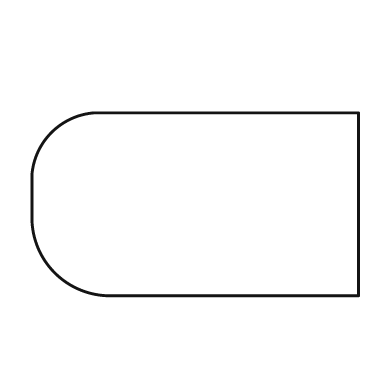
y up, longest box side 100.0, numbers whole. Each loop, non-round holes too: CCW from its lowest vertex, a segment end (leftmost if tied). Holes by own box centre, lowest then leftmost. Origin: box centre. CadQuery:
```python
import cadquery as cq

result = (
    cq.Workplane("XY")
    .moveTo(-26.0, -28.0)
    .lineTo(50.0, -28.0)
    .lineTo(50.0, 28.0)
    .lineTo(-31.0, 28.0)
    .threePointArc((-44.0, 22.0), (-50.0, 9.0))
    .lineTo(-50.0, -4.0)
    .threePointArc((-43.0, -21.0), (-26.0, -28.0))
    .close()
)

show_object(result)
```